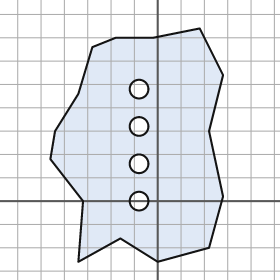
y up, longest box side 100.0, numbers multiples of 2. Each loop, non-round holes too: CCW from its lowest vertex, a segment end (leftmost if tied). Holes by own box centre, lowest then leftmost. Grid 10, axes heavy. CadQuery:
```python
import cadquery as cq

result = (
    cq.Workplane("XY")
    .moveTo(-34.0, -26.0)
    .lineTo(-16.0, -16.0)
    .lineTo(0.0, -26.0)
    .lineTo(22.0, -20.0)
    .lineTo(28.0, 2.0)
    .lineTo(22.0, 30.0)
    .lineTo(28.0, 54.0)
    .lineTo(18.0, 74.0)
    .lineTo(-2.0, 70.0)
    .lineTo(-18.0, 70.0)
    .lineTo(-28.0, 66.0)
    .lineTo(-34.0, 46.0)
    .lineTo(-44.0, 30.0)
    .lineTo(-46.0, 18.0)
    .lineTo(-32.0, 0.0)
    .close()
    .moveTo(-8.0, 0.0)
    .circle(4.0)
    .moveTo(-8.0, 16.0)
    .circle(4.0)
    .moveTo(-8.0, 32.0)
    .circle(4.0)
    .moveTo(-8.0, 48.0)
    .circle(4.0)
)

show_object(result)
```